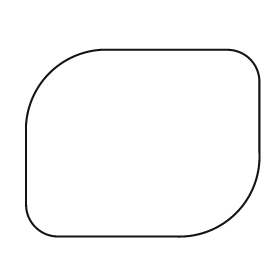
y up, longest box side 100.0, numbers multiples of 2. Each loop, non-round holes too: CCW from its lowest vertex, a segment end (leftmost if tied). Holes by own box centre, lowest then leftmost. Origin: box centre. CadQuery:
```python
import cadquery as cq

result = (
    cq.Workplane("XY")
    .moveTo(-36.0, -40.0)
    .lineTo(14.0, -40.0)
    .threePointArc((40.0, -30.0), (50.0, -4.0))
    .lineTo(50.0, 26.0)
    .threePointArc((46.0, 36.0), (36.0, 40.0))
    .lineTo(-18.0, 40.0)
    .threePointArc((-40.0, 30.0), (-50.0, 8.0))
    .lineTo(-50.0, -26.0)
    .threePointArc((-46.0, -36.0), (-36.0, -40.0))
    .close()
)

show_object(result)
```